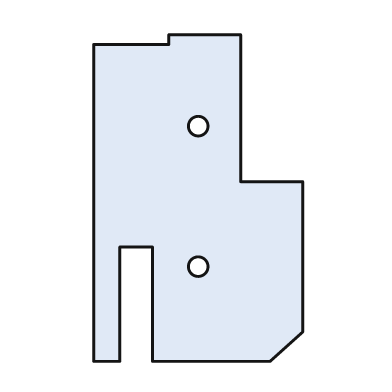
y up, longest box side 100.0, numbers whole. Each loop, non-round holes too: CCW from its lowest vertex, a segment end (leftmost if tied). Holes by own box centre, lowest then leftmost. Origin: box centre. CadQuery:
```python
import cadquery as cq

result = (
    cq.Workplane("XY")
    .moveTo(-32.0, -50.0)
    .lineTo(-24.0, -50.0)
    .lineTo(-24.0, -15.0)
    .lineTo(-14.0, -15.0)
    .lineTo(-14.0, -50.0)
    .lineTo(22.0, -50.0)
    .lineTo(32.0, -41.0)
    .lineTo(32.0, 5.0)
    .lineTo(13.0, 5.0)
    .lineTo(13.0, 50.0)
    .lineTo(-9.0, 50.0)
    .lineTo(-9.0, 47.0)
    .lineTo(-32.0, 47.0)
    .close()
    .moveTo(0.0, -21.0)
    .circle(3.0)
    .moveTo(0.0, 22.0)
    .circle(3.0)
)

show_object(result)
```